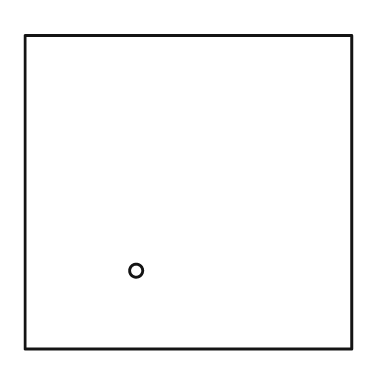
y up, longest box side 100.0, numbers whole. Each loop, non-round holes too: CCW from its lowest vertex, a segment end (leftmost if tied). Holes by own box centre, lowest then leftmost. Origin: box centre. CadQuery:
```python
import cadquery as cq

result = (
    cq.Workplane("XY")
    .moveTo(-50.0, -48.0)
    .lineTo(50.0, -48.0)
    .lineTo(50.0, 48.0)
    .lineTo(-50.0, 48.0)
    .close()
    .moveTo(-16.0, -24.0)
    .circle(2.0)
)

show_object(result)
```